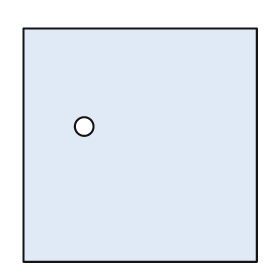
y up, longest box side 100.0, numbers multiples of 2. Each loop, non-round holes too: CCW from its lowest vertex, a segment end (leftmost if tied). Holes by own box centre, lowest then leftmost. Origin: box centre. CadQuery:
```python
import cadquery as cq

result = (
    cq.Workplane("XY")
    .moveTo(-50.0, -50.0)
    .lineTo(50.0, -50.0)
    .lineTo(50.0, 50.0)
    .lineTo(-50.0, 50.0)
    .close()
    .moveTo(-24.0, 8.0)
    .circle(4.0)
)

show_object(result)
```